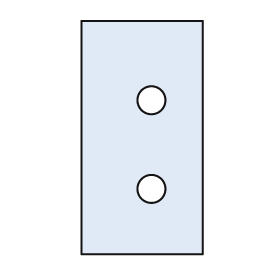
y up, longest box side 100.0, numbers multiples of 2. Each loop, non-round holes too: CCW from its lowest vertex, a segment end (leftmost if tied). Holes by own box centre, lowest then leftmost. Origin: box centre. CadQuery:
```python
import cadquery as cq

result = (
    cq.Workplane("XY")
    .moveTo(-26.0, -50.0)
    .lineTo(26.0, -50.0)
    .lineTo(26.0, 50.0)
    .lineTo(-26.0, 50.0)
    .close()
    .moveTo(4.0, -22.0)
    .circle(6.0)
    .moveTo(4.0, 16.0)
    .circle(6.0)
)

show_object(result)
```